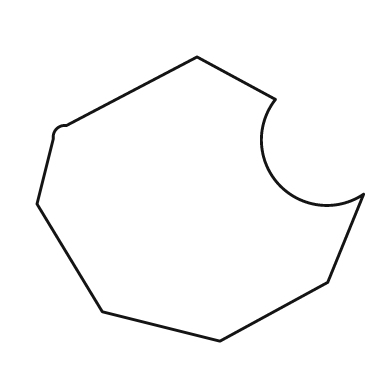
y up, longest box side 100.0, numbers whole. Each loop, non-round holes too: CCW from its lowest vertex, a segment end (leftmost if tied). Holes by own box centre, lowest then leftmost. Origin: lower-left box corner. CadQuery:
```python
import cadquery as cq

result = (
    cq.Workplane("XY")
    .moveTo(56.0, 0.0)
    .lineTo(89.0, 18.0)
    .lineTo(100.0, 45.0)
    .threePointArc((74.0, 48.0), (73.0, 74.0))
    .lineTo(49.0, 87.0)
    .lineTo(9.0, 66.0)
    .threePointArc((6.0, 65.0), (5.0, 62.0))
    .lineTo(0.0, 42.0)
    .lineTo(20.0, 9.0)
    .close()
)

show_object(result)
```